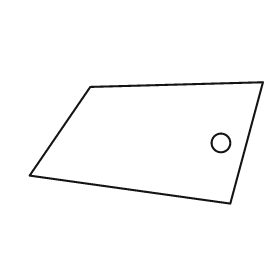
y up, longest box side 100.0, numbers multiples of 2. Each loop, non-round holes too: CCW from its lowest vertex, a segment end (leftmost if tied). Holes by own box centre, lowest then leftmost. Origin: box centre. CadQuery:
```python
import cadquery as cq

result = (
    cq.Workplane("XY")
    .moveTo(36.0, -26.0)
    .lineTo(50.0, 26.0)
    .lineTo(-24.0, 24.0)
    .lineTo(-50.0, -14.0)
    .close()
    .moveTo(32.0, 0.0)
    .circle(4.0)
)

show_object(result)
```